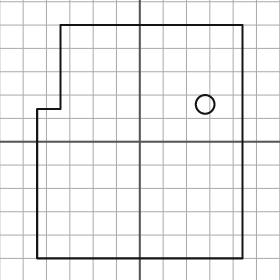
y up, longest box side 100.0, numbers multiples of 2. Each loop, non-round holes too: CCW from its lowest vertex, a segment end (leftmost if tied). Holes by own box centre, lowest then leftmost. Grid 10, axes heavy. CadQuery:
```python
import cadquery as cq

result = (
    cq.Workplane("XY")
    .moveTo(-44.0, -50.0)
    .lineTo(44.0, -50.0)
    .lineTo(44.0, 50.0)
    .lineTo(-34.0, 50.0)
    .lineTo(-34.0, 14.0)
    .lineTo(-44.0, 14.0)
    .close()
    .moveTo(28.0, 16.0)
    .circle(4.0)
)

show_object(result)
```